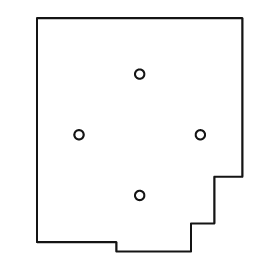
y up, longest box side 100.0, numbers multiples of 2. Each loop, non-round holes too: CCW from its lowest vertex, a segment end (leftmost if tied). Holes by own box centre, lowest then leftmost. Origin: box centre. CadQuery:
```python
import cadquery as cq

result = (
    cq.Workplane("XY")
    .moveTo(-10.0, -50.0)
    .lineTo(22.0, -50.0)
    .lineTo(22.0, -38.0)
    .lineTo(32.0, -38.0)
    .lineTo(32.0, -18.0)
    .lineTo(44.0, -18.0)
    .lineTo(44.0, 50.0)
    .lineTo(-44.0, 50.0)
    .lineTo(-44.0, -46.0)
    .lineTo(-10.0, -46.0)
    .close()
    .moveTo(0.0, -26.0)
    .circle(2.0)
    .moveTo(-26.0, 0.0)
    .circle(2.0)
    .moveTo(26.0, 0.0)
    .circle(2.0)
    .moveTo(0.0, 26.0)
    .circle(2.0)
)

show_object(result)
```